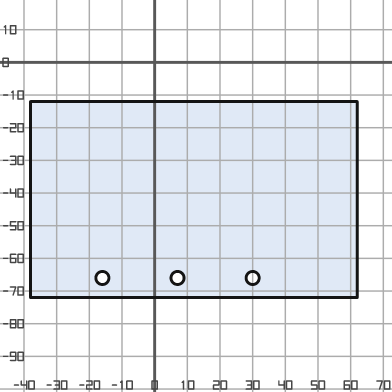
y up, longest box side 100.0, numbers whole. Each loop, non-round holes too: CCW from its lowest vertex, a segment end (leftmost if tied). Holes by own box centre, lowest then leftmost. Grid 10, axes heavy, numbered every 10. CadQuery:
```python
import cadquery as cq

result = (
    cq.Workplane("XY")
    .moveTo(-38.0, -72.0)
    .lineTo(62.0, -72.0)
    .lineTo(62.0, -12.0)
    .lineTo(-38.0, -12.0)
    .close()
    .moveTo(-16.0, -66.0)
    .circle(2.0)
    .moveTo(7.0, -66.0)
    .circle(2.0)
    .moveTo(30.0, -66.0)
    .circle(2.0)
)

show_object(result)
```